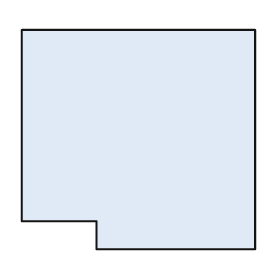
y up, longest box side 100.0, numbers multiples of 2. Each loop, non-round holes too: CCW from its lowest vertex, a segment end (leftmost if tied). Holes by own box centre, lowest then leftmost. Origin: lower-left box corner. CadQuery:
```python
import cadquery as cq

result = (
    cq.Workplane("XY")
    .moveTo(32.0, 0.0)
    .lineTo(100.0, 0.0)
    .lineTo(100.0, 94.0)
    .lineTo(0.0, 94.0)
    .lineTo(0.0, 12.0)
    .lineTo(32.0, 12.0)
    .close()
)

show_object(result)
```